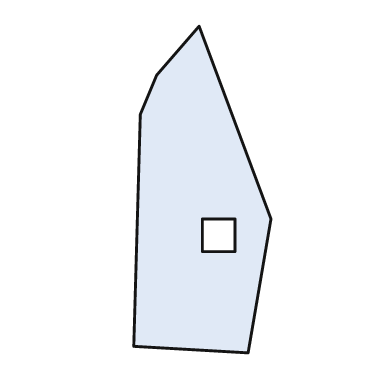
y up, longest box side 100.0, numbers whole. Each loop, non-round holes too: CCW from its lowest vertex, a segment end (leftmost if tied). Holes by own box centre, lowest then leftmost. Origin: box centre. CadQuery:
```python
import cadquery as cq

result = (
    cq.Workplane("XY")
    .moveTo(14.0, -50.0)
    .lineTo(21.0, -9.0)
    .lineTo(-1.0, 50.0)
    .lineTo(-14.0, 35.0)
    .lineTo(-19.0, 23.0)
    .lineTo(-21.0, -48.0)
    .close()
    .moveTo(0.0, -19.0)
    .lineTo(10.0, -19.0)
    .lineTo(10.0, -9.0)
    .lineTo(0.0, -9.0)
    .close()
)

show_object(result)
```